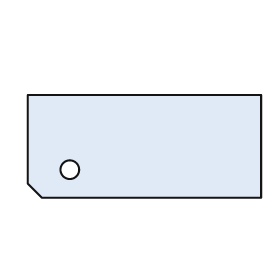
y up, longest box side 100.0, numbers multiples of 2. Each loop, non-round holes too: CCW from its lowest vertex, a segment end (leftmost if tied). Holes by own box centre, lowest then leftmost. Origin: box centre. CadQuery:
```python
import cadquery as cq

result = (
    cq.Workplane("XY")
    .moveTo(-44.0, -22.0)
    .lineTo(50.0, -22.0)
    .lineTo(50.0, 22.0)
    .lineTo(-50.0, 22.0)
    .lineTo(-50.0, -16.0)
    .close()
    .moveTo(-32.0, -10.0)
    .circle(4.0)
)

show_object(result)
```